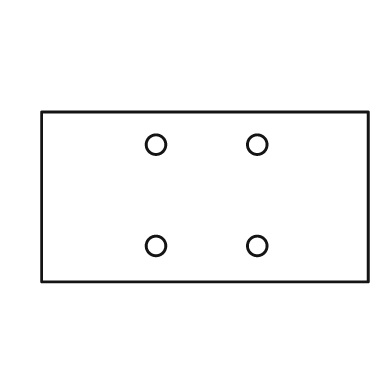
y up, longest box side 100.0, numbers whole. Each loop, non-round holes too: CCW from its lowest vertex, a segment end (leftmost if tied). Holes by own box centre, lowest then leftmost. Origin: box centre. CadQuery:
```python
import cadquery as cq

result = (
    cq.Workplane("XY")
    .moveTo(-50.0, -26.0)
    .lineTo(50.0, -26.0)
    .lineTo(50.0, 26.0)
    .lineTo(-50.0, 26.0)
    .close()
    .moveTo(-15.0, -15.0)
    .circle(3.0)
    .moveTo(16.0, -15.0)
    .circle(3.0)
    .moveTo(-15.0, 16.0)
    .circle(3.0)
    .moveTo(16.0, 16.0)
    .circle(3.0)
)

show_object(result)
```